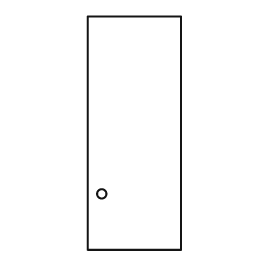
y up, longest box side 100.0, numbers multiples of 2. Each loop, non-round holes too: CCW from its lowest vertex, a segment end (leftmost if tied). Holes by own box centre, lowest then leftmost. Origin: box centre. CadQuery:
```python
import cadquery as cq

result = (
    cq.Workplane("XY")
    .moveTo(-20.0, -50.0)
    .lineTo(20.0, -50.0)
    .lineTo(20.0, 50.0)
    .lineTo(-20.0, 50.0)
    .close()
    .moveTo(-14.0, -26.0)
    .circle(2.0)
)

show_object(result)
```